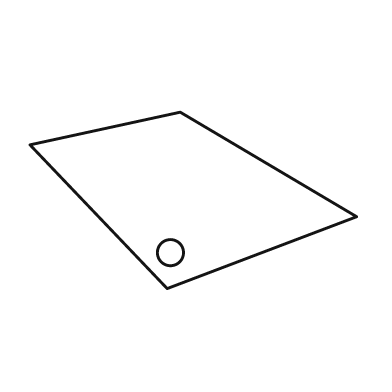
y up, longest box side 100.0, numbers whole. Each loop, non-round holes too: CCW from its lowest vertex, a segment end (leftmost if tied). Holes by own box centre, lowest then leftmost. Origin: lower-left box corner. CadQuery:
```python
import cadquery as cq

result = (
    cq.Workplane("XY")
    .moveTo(42.0, 0.0)
    .lineTo(100.0, 22.0)
    .lineTo(46.0, 54.0)
    .lineTo(0.0, 44.0)
    .close()
    .moveTo(43.0, 11.0)
    .circle(4.0)
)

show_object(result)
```